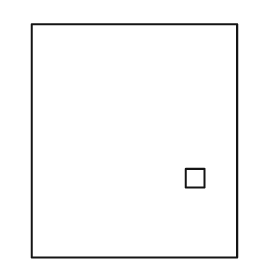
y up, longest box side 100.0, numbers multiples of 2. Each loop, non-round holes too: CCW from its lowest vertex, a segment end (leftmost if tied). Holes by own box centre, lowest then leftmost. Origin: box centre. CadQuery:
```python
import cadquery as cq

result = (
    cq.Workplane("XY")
    .moveTo(-44.0, -50.0)
    .lineTo(44.0, -50.0)
    .lineTo(44.0, 50.0)
    .lineTo(-44.0, 50.0)
    .close()
    .moveTo(22.0, -20.0)
    .lineTo(30.0, -20.0)
    .lineTo(30.0, -12.0)
    .lineTo(22.0, -12.0)
    .close()
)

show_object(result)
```